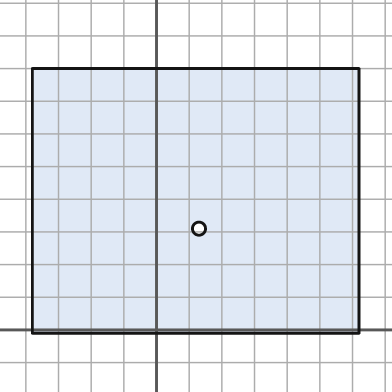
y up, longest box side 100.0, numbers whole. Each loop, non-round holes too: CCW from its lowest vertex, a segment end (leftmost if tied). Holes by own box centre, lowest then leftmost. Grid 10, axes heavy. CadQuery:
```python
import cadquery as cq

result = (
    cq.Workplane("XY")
    .moveTo(-38.0, -1.0)
    .lineTo(62.0, -1.0)
    .lineTo(62.0, 80.0)
    .lineTo(-38.0, 80.0)
    .close()
    .moveTo(13.0, 31.0)
    .circle(2.0)
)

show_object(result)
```